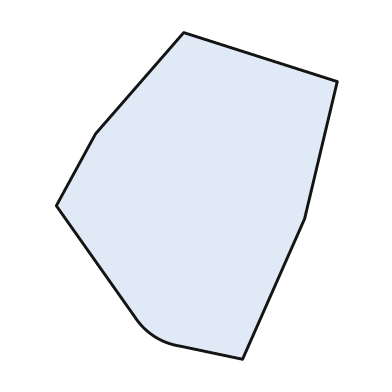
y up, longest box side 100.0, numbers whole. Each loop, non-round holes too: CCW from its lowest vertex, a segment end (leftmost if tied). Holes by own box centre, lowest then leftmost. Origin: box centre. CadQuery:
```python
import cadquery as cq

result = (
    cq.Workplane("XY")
    .moveTo(14.0, -50.0)
    .lineTo(33.0, -7.0)
    .lineTo(43.0, 35.0)
    .lineTo(-4.0, 50.0)
    .lineTo(-31.0, 19.0)
    .lineTo(-43.0, -3.0)
    .lineTo(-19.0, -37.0)
    .threePointArc((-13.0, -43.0), (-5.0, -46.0))
    .close()
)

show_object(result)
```